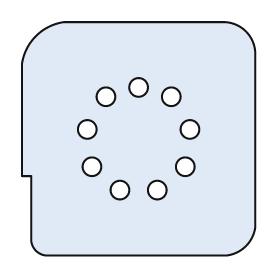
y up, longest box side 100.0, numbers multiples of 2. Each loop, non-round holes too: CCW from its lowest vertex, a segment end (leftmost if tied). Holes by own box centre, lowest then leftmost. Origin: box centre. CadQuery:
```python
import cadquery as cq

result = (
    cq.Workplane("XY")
    .moveTo(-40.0, -50.0)
    .lineTo(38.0, -50.0)
    .threePointArc((46.0, -46.0), (50.0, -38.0))
    .lineTo(50.0, 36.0)
    .threePointArc((46.0, 46.0), (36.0, 50.0))
    .lineTo(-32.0, 50.0)
    .threePointArc((-44.0, 44.0), (-50.0, 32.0))
    .lineTo(-50.0, -16.0)
    .lineTo(-46.0, -16.0)
    .lineTo(-46.0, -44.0)
    .threePointArc((-44.0, -48.0), (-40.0, -50.0))
    .close()
    .moveTo(-8.0, -22.0)
    .circle(4.0)
    .moveTo(8.0, -22.0)
    .circle(4.0)
    .moveTo(-20.0, -12.0)
    .circle(4.0)
    .moveTo(20.0, -12.0)
    .circle(4.0)
    .moveTo(-22.0, 4.0)
    .circle(4.0)
    .moveTo(22.0, 4.0)
    .circle(4.0)
    .moveTo(-14.0, 18.0)
    .circle(4.0)
    .moveTo(14.0, 18.0)
    .circle(4.0)
    .moveTo(0.0, 22.0)
    .circle(4.0)
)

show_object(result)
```